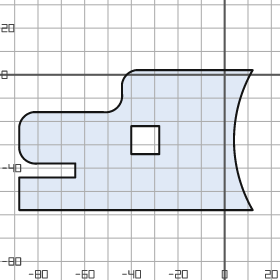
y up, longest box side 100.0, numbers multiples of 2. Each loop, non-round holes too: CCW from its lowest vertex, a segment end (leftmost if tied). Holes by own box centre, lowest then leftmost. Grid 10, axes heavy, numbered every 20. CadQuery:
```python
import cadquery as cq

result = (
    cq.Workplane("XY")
    .moveTo(-88.0, -58.0)
    .lineTo(12.0, -58.0)
    .threePointArc((4.0, -28.0), (12.0, 2.0))
    .lineTo(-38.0, 2.0)
    .threePointArc((-42.0, 0.0), (-44.0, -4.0))
    .lineTo(-44.0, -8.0)
    .threePointArc((-46.0, -14.0), (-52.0, -16.0))
    .lineTo(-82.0, -16.0)
    .threePointArc((-86.0, -18.0), (-88.0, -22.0))
    .lineTo(-88.0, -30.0)
    .threePointArc((-86.0, -36.0), (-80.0, -38.0))
    .lineTo(-64.0, -38.0)
    .lineTo(-64.0, -44.0)
    .lineTo(-88.0, -44.0)
    .close()
    .moveTo(-40.0, -34.0)
    .lineTo(-28.0, -34.0)
    .lineTo(-28.0, -22.0)
    .lineTo(-40.0, -22.0)
    .close()
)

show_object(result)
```